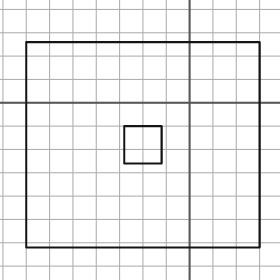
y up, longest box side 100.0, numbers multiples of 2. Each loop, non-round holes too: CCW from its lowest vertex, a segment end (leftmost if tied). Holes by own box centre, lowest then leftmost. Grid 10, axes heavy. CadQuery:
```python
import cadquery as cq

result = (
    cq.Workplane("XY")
    .moveTo(-70.0, -62.0)
    .lineTo(30.0, -62.0)
    .lineTo(30.0, 26.0)
    .lineTo(-70.0, 26.0)
    .close()
    .moveTo(-28.0, -26.0)
    .lineTo(-12.0, -26.0)
    .lineTo(-12.0, -10.0)
    .lineTo(-28.0, -10.0)
    .close()
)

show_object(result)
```